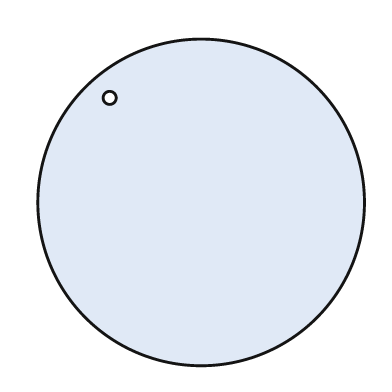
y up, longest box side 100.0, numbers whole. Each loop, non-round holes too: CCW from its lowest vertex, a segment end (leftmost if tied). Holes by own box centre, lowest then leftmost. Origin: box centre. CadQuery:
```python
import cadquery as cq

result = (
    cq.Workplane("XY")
    .moveTo(0.0, 0.0)
    .circle(50.0)
    .moveTo(-28.0, 32.0)
    .circle(2.0)
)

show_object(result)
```